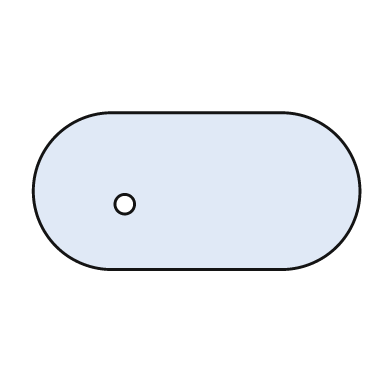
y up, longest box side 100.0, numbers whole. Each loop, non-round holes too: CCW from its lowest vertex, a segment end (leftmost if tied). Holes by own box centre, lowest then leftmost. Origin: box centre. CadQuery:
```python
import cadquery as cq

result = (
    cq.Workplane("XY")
    .moveTo(-26.0, -24.0)
    .lineTo(26.0, -24.0)
    .threePointArc((50.0, 0.0), (26.0, 24.0))
    .lineTo(-26.0, 24.0)
    .threePointArc((-50.0, 0.0), (-26.0, -24.0))
    .close()
    .moveTo(-22.0, -4.0)
    .circle(3.0)
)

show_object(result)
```